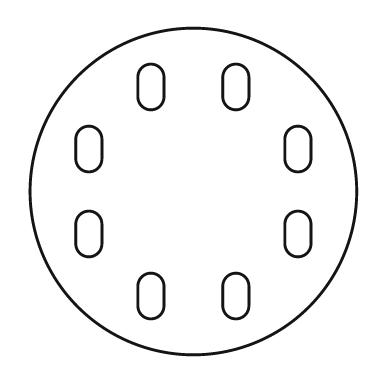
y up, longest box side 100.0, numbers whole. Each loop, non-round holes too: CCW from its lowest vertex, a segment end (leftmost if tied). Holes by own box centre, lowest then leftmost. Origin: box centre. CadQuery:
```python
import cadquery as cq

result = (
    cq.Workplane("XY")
    .moveTo(0.0, 0.0)
    .circle(50.0)
    .moveTo(-17.0, -35.0)
    .threePointArc((-13.0, -39.0), (-9.0, -35.0))
    .lineTo(-9.0, -29.0)
    .threePointArc((-13.0, -25.0), (-17.0, -29.0))
    .close()
    .moveTo(9.0, -35.0)
    .threePointArc((13.0, -39.0), (17.0, -35.0))
    .lineTo(17.0, -29.0)
    .threePointArc((13.0, -25.0), (9.0, -29.0))
    .close()
    .moveTo(-36.0, -16.0)
    .threePointArc((-32.0, -20.0), (-28.0, -16.0))
    .lineTo(-28.0, -10.0)
    .threePointArc((-32.0, -6.0), (-36.0, -10.0))
    .close()
    .moveTo(28.0, -16.0)
    .threePointArc((32.0, -20.0), (36.0, -16.0))
    .lineTo(36.0, -10.0)
    .threePointArc((32.0, -6.0), (28.0, -10.0))
    .close()
    .moveTo(-36.0, 10.0)
    .threePointArc((-32.0, 6.0), (-28.0, 10.0))
    .lineTo(-28.0, 16.0)
    .threePointArc((-32.0, 20.0), (-36.0, 16.0))
    .close()
    .moveTo(28.0, 10.0)
    .threePointArc((32.0, 6.0), (36.0, 10.0))
    .lineTo(36.0, 16.0)
    .threePointArc((32.0, 20.0), (28.0, 16.0))
    .close()
    .moveTo(-17.0, 29.0)
    .threePointArc((-13.0, 25.0), (-9.0, 29.0))
    .lineTo(-9.0, 35.0)
    .threePointArc((-13.0, 39.0), (-17.0, 35.0))
    .close()
    .moveTo(9.0, 29.0)
    .threePointArc((13.0, 25.0), (17.0, 29.0))
    .lineTo(17.0, 35.0)
    .threePointArc((13.0, 39.0), (9.0, 35.0))
    .close()
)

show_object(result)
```